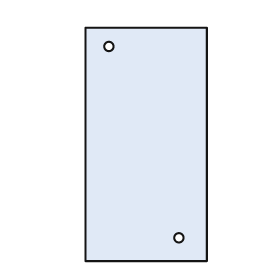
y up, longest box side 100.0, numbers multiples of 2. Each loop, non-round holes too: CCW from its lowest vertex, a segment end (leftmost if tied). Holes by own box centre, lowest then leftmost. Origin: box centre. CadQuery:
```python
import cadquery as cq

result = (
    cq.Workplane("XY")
    .moveTo(-26.0, -50.0)
    .lineTo(26.0, -50.0)
    .lineTo(26.0, 50.0)
    .lineTo(-26.0, 50.0)
    .close()
    .moveTo(14.0, -40.0)
    .circle(2.0)
    .moveTo(-16.0, 42.0)
    .circle(2.0)
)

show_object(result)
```